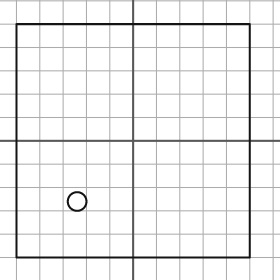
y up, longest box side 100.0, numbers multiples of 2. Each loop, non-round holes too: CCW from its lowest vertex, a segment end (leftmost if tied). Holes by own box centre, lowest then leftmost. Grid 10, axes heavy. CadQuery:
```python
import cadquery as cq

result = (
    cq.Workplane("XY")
    .moveTo(-50.0, -50.0)
    .lineTo(50.0, -50.0)
    .lineTo(50.0, 50.0)
    .lineTo(-50.0, 50.0)
    .close()
    .moveTo(-24.0, -26.0)
    .circle(4.0)
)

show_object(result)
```